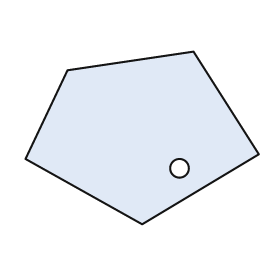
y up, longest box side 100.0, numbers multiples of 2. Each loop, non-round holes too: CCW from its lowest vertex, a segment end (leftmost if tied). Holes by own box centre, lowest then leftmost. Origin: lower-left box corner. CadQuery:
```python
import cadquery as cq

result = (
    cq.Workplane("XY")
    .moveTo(50.0, 0.0)
    .lineTo(100.0, 30.0)
    .lineTo(72.0, 74.0)
    .lineTo(18.0, 66.0)
    .lineTo(0.0, 28.0)
    .close()
    .moveTo(66.0, 24.0)
    .circle(4.0)
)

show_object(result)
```